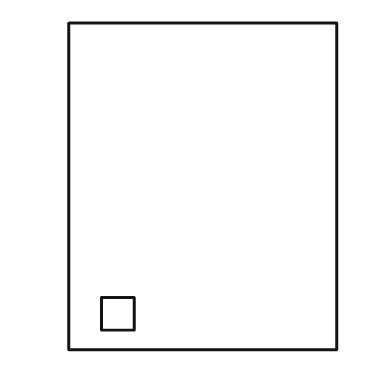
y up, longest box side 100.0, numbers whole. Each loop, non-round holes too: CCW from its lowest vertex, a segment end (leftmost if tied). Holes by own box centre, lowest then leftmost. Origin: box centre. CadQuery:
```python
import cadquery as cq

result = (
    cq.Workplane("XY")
    .moveTo(-41.0, -50.0)
    .lineTo(41.0, -50.0)
    .lineTo(41.0, 50.0)
    .lineTo(-41.0, 50.0)
    .close()
    .moveTo(-31.0, -44.0)
    .lineTo(-21.0, -44.0)
    .lineTo(-21.0, -34.0)
    .lineTo(-31.0, -34.0)
    .close()
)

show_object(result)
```